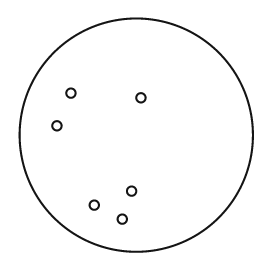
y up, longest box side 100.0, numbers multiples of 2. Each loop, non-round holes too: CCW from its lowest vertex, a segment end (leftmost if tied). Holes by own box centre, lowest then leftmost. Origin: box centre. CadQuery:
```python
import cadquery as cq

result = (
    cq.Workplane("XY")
    .moveTo(0.0, 0.0)
    .circle(50.0)
    .moveTo(-6.0, -36.0)
    .circle(2.0)
    .moveTo(-18.0, -30.0)
    .circle(2.0)
    .moveTo(-2.0, -24.0)
    .circle(2.0)
    .moveTo(-34.0, 4.0)
    .circle(2.0)
    .moveTo(2.0, 16.0)
    .circle(2.0)
    .moveTo(-28.0, 18.0)
    .circle(2.0)
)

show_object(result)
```